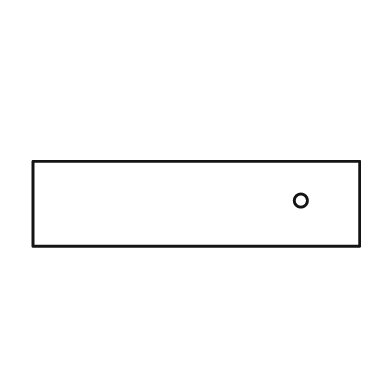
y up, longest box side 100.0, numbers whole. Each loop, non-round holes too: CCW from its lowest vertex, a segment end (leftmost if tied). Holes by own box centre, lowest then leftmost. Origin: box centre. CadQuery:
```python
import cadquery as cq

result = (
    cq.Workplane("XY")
    .moveTo(-50.0, -13.0)
    .lineTo(50.0, -13.0)
    .lineTo(50.0, 13.0)
    .lineTo(-50.0, 13.0)
    .close()
    .moveTo(32.0, 1.0)
    .circle(2.0)
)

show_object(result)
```